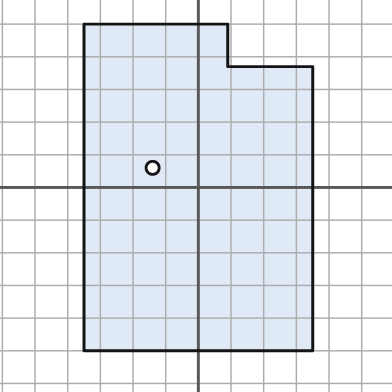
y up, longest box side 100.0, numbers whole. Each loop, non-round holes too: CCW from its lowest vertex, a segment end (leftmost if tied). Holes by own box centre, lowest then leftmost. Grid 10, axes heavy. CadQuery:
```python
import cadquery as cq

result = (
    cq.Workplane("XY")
    .moveTo(-35.0, -50.0)
    .lineTo(35.0, -50.0)
    .lineTo(35.0, 37.0)
    .lineTo(9.0, 37.0)
    .lineTo(9.0, 50.0)
    .lineTo(-35.0, 50.0)
    .close()
    .moveTo(-14.0, 6.0)
    .circle(2.0)
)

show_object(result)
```